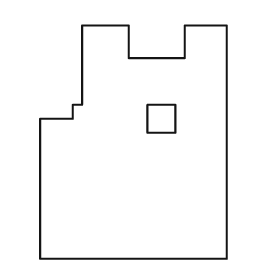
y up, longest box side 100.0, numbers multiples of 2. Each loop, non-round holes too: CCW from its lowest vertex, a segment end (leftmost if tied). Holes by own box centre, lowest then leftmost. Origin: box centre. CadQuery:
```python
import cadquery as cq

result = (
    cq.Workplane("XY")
    .moveTo(-40.0, -50.0)
    .lineTo(40.0, -50.0)
    .lineTo(40.0, 50.0)
    .lineTo(22.0, 50.0)
    .lineTo(22.0, 36.0)
    .lineTo(-2.0, 36.0)
    .lineTo(-2.0, 50.0)
    .lineTo(-22.0, 50.0)
    .lineTo(-22.0, 16.0)
    .lineTo(-26.0, 16.0)
    .lineTo(-26.0, 10.0)
    .lineTo(-40.0, 10.0)
    .close()
    .moveTo(6.0, 4.0)
    .lineTo(18.0, 4.0)
    .lineTo(18.0, 16.0)
    .lineTo(6.0, 16.0)
    .close()
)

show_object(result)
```